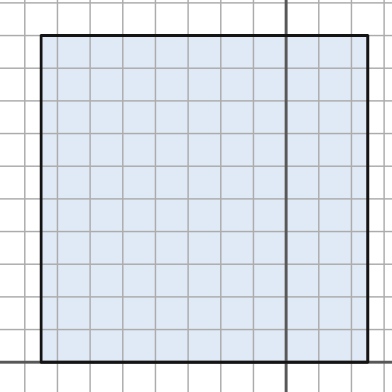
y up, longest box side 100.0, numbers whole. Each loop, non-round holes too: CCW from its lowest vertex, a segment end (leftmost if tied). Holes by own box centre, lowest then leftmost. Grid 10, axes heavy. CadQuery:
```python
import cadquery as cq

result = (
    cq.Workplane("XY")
    .moveTo(-75.0, 0.0)
    .lineTo(25.0, 0.0)
    .lineTo(25.0, 100.0)
    .lineTo(-75.0, 100.0)
    .close()
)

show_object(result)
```